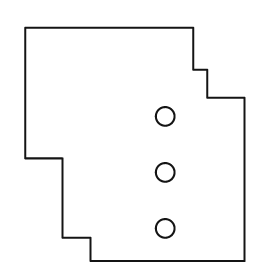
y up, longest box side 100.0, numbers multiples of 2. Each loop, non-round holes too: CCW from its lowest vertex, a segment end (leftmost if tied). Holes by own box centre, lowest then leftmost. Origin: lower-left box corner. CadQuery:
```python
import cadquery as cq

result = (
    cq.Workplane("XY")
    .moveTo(28.0, 0.0)
    .lineTo(94.0, 0.0)
    .lineTo(94.0, 70.0)
    .lineTo(78.0, 70.0)
    .lineTo(78.0, 82.0)
    .lineTo(72.0, 82.0)
    .lineTo(72.0, 100.0)
    .lineTo(0.0, 100.0)
    .lineTo(0.0, 44.0)
    .lineTo(16.0, 44.0)
    .lineTo(16.0, 10.0)
    .lineTo(28.0, 10.0)
    .close()
    .moveTo(60.0, 14.0)
    .circle(4.0)
    .moveTo(60.0, 38.0)
    .circle(4.0)
    .moveTo(60.0, 62.0)
    .circle(4.0)
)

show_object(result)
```